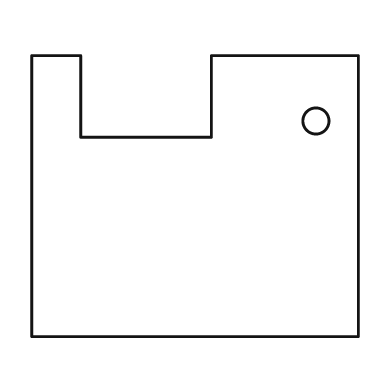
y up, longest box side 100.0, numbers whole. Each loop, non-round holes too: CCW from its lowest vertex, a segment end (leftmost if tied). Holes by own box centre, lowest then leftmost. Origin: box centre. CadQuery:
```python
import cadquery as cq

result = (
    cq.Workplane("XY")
    .moveTo(-50.0, -43.0)
    .lineTo(50.0, -43.0)
    .lineTo(50.0, 43.0)
    .lineTo(5.0, 43.0)
    .lineTo(5.0, 18.0)
    .lineTo(-35.0, 18.0)
    .lineTo(-35.0, 43.0)
    .lineTo(-50.0, 43.0)
    .close()
    .moveTo(37.0, 23.0)
    .circle(4.0)
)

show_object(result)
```